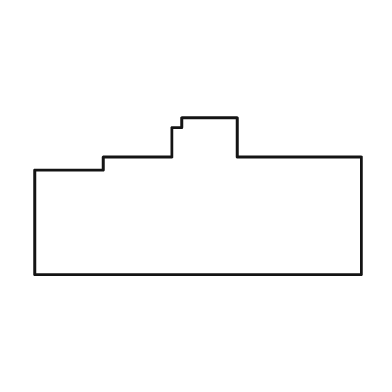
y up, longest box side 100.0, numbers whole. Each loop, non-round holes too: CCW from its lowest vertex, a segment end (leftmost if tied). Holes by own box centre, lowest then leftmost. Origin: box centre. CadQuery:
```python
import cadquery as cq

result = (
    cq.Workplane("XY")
    .moveTo(-50.0, -24.0)
    .lineTo(50.0, -24.0)
    .lineTo(50.0, 12.0)
    .lineTo(12.0, 12.0)
    .lineTo(12.0, 24.0)
    .lineTo(-5.0, 24.0)
    .lineTo(-5.0, 21.0)
    .lineTo(-8.0, 21.0)
    .lineTo(-8.0, 12.0)
    .lineTo(-29.0, 12.0)
    .lineTo(-29.0, 8.0)
    .lineTo(-50.0, 8.0)
    .close()
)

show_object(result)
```